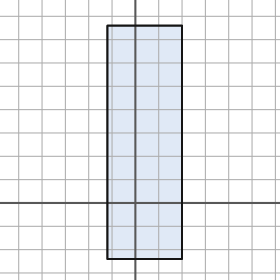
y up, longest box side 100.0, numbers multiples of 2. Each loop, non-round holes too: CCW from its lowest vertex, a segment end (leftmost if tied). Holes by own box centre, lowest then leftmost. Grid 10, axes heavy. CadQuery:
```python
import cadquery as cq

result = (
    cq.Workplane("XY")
    .moveTo(-12.0, -24.0)
    .lineTo(20.0, -24.0)
    .lineTo(20.0, 76.0)
    .lineTo(-12.0, 76.0)
    .close()
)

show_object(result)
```